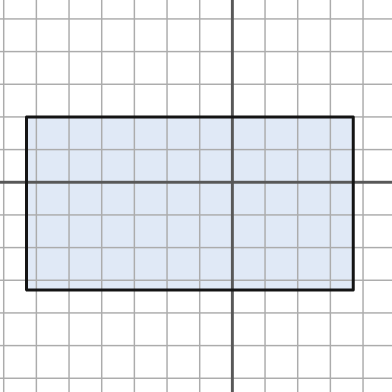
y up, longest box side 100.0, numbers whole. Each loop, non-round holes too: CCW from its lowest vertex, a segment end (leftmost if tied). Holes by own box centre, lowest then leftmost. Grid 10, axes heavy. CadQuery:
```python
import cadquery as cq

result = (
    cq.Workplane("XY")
    .moveTo(-63.0, -33.0)
    .lineTo(37.0, -33.0)
    .lineTo(37.0, 20.0)
    .lineTo(-63.0, 20.0)
    .close()
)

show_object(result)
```